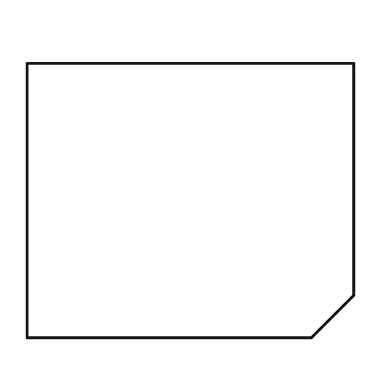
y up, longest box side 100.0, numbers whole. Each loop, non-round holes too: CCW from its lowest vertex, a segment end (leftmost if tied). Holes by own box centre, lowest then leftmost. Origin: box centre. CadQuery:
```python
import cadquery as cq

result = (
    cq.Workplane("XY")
    .moveTo(-50.0, -42.0)
    .lineTo(37.0, -42.0)
    .lineTo(50.0, -29.0)
    .lineTo(50.0, 42.0)
    .lineTo(-50.0, 42.0)
    .close()
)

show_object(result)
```